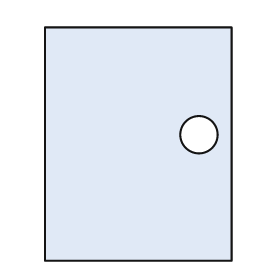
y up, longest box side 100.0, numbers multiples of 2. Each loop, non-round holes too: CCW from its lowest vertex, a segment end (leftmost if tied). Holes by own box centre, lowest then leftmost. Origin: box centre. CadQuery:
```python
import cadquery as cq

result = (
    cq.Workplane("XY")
    .moveTo(-40.0, -50.0)
    .lineTo(40.0, -50.0)
    .lineTo(40.0, 50.0)
    .lineTo(-40.0, 50.0)
    .close()
    .moveTo(26.0, 4.0)
    .circle(8.0)
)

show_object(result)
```